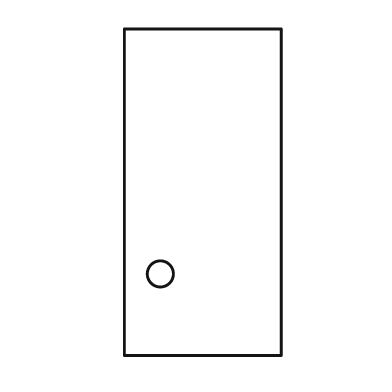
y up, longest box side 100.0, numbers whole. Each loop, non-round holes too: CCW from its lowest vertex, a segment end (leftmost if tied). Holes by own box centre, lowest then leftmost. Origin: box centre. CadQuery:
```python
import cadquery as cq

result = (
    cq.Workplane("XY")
    .moveTo(-24.0, -50.0)
    .lineTo(24.0, -50.0)
    .lineTo(24.0, 50.0)
    .lineTo(-24.0, 50.0)
    .close()
    .moveTo(-13.0, -25.0)
    .circle(4.0)
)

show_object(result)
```